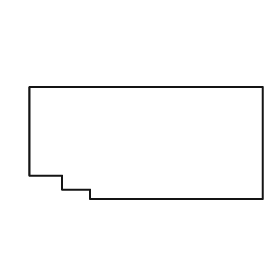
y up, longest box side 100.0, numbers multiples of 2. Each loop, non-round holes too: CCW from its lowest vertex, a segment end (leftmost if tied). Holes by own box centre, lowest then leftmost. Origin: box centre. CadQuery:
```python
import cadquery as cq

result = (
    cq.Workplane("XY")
    .moveTo(-24.0, -24.0)
    .lineTo(50.0, -24.0)
    .lineTo(50.0, 24.0)
    .lineTo(-50.0, 24.0)
    .lineTo(-50.0, -14.0)
    .lineTo(-36.0, -14.0)
    .lineTo(-36.0, -20.0)
    .lineTo(-24.0, -20.0)
    .close()
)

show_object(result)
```